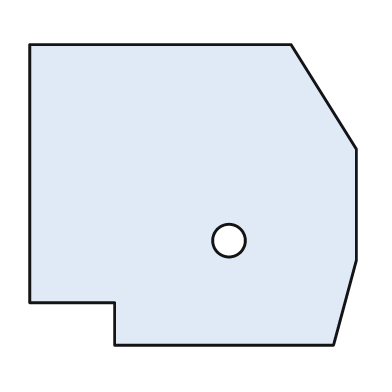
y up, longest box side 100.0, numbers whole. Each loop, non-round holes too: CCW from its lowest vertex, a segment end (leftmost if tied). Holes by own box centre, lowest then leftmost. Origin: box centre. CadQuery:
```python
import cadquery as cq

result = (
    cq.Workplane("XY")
    .moveTo(-24.0, -46.0)
    .lineTo(43.0, -46.0)
    .lineTo(50.0, -20.0)
    .lineTo(50.0, 14.0)
    .lineTo(30.0, 46.0)
    .lineTo(-50.0, 46.0)
    .lineTo(-50.0, -33.0)
    .lineTo(-24.0, -33.0)
    .close()
    .moveTo(11.0, -14.0)
    .circle(5.0)
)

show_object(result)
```